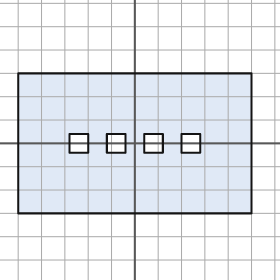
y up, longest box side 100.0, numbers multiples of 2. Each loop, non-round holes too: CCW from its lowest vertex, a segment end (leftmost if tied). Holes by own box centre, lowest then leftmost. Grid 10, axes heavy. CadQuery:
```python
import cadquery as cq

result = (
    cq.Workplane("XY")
    .moveTo(-50.0, -30.0)
    .lineTo(50.0, -30.0)
    .lineTo(50.0, 30.0)
    .lineTo(-50.0, 30.0)
    .close()
    .moveTo(-28.0, -4.0)
    .lineTo(-20.0, -4.0)
    .lineTo(-20.0, 4.0)
    .lineTo(-28.0, 4.0)
    .close()
    .moveTo(-12.0, -4.0)
    .lineTo(-4.0, -4.0)
    .lineTo(-4.0, 4.0)
    .lineTo(-12.0, 4.0)
    .close()
    .moveTo(4.0, -4.0)
    .lineTo(12.0, -4.0)
    .lineTo(12.0, 4.0)
    .lineTo(4.0, 4.0)
    .close()
    .moveTo(20.0, -4.0)
    .lineTo(28.0, -4.0)
    .lineTo(28.0, 4.0)
    .lineTo(20.0, 4.0)
    .close()
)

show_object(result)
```